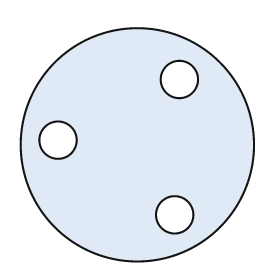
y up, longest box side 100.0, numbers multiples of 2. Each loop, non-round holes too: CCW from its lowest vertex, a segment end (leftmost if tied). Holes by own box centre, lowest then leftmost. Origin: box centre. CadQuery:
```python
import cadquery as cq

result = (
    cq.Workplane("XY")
    .moveTo(0.0, 0.0)
    .circle(50.0)
    .moveTo(16.0, -30.0)
    .circle(8.0)
    .moveTo(-34.0, 2.0)
    .circle(8.0)
    .moveTo(18.0, 28.0)
    .circle(8.0)
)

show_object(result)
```